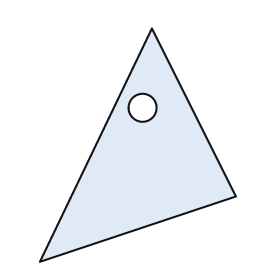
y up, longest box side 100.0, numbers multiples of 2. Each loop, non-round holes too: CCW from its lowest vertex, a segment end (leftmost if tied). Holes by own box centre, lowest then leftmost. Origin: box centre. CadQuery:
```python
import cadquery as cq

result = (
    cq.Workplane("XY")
    .moveTo(-42.0, -50.0)
    .lineTo(42.0, -22.0)
    .lineTo(6.0, 50.0)
    .close()
    .moveTo(2.0, 16.0)
    .circle(6.0)
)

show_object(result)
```